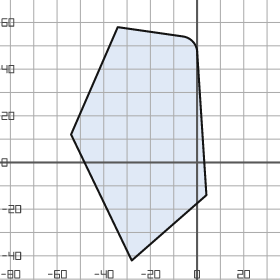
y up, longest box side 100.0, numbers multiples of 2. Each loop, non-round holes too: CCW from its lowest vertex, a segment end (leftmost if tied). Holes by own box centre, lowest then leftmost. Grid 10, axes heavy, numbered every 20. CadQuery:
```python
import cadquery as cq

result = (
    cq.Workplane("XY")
    .moveTo(-28.0, -42.0)
    .lineTo(4.0, -14.0)
    .lineTo(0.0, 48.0)
    .threePointArc((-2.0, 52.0), (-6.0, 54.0))
    .lineTo(-34.0, 58.0)
    .lineTo(-54.0, 12.0)
    .close()
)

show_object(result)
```